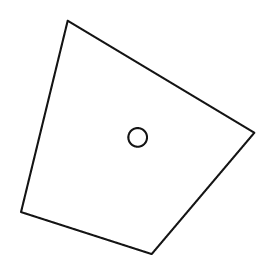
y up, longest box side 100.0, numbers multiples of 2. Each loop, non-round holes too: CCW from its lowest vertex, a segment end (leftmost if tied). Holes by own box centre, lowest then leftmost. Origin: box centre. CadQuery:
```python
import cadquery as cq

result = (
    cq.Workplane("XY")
    .moveTo(6.0, -50.0)
    .lineTo(50.0, 2.0)
    .lineTo(-30.0, 50.0)
    .lineTo(-50.0, -32.0)
    .close()
    .moveTo(0.0, 0.0)
    .circle(4.0)
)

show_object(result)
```